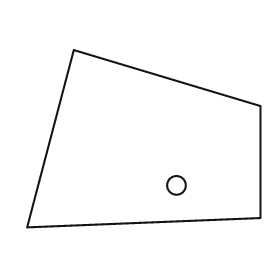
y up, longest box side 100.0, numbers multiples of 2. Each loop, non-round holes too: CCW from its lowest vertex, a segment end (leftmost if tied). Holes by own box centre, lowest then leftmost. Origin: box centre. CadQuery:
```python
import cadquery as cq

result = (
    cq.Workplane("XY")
    .moveTo(-50.0, -38.0)
    .lineTo(50.0, -34.0)
    .lineTo(50.0, 14.0)
    .lineTo(-30.0, 38.0)
    .close()
    .moveTo(14.0, -20.0)
    .circle(4.0)
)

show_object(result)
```